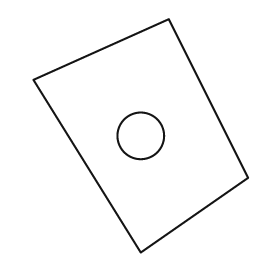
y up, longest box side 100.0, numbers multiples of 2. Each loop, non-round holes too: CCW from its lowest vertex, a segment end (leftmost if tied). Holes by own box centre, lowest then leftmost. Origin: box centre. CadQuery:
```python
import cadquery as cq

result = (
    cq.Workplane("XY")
    .moveTo(0.0, -50.0)
    .lineTo(46.0, -18.0)
    .lineTo(12.0, 50.0)
    .lineTo(-46.0, 24.0)
    .close()
    .moveTo(0.0, 0.0)
    .circle(10.0)
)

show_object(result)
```